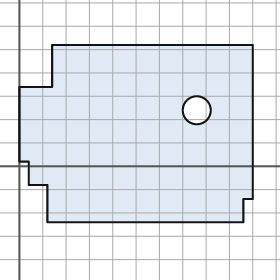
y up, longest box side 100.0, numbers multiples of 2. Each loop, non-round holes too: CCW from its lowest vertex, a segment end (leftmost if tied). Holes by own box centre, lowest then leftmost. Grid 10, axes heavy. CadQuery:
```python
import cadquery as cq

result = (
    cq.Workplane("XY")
    .moveTo(12.0, -24.0)
    .lineTo(96.0, -24.0)
    .lineTo(96.0, -14.0)
    .lineTo(100.0, -14.0)
    .lineTo(100.0, 52.0)
    .lineTo(14.0, 52.0)
    .lineTo(14.0, 34.0)
    .lineTo(0.0, 34.0)
    .lineTo(0.0, 2.0)
    .lineTo(4.0, 2.0)
    .lineTo(4.0, -8.0)
    .lineTo(12.0, -8.0)
    .close()
    .moveTo(76.0, 24.0)
    .circle(6.0)
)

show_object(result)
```